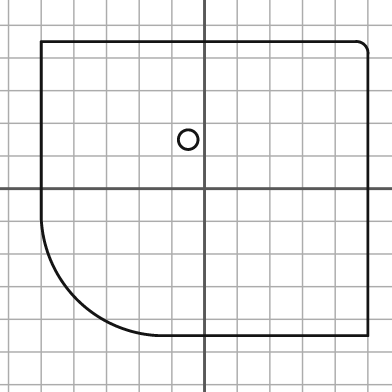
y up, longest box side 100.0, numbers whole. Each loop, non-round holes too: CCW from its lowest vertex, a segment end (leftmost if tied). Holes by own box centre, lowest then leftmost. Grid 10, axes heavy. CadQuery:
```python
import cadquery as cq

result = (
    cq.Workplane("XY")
    .moveTo(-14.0, -45.0)
    .lineTo(50.0, -45.0)
    .lineTo(50.0, 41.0)
    .threePointArc((49.0, 44.0), (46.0, 45.0))
    .lineTo(-50.0, 45.0)
    .lineTo(-50.0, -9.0)
    .threePointArc((-39.0, -34.0), (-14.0, -45.0))
    .close()
    .moveTo(-5.0, 15.0)
    .circle(3.0)
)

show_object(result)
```